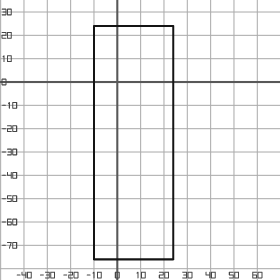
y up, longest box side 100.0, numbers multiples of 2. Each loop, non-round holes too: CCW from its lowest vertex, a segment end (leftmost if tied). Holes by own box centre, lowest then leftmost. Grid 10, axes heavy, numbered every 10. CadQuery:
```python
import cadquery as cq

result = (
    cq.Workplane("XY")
    .moveTo(-10.0, -76.0)
    .lineTo(24.0, -76.0)
    .lineTo(24.0, 24.0)
    .lineTo(-10.0, 24.0)
    .close()
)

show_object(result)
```